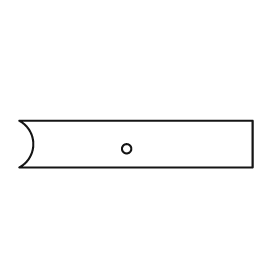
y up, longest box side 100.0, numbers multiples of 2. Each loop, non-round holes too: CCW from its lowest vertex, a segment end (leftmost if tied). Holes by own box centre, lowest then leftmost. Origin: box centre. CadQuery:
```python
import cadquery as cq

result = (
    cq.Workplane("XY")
    .moveTo(-50.0, -10.0)
    .lineTo(50.0, -10.0)
    .lineTo(50.0, 10.0)
    .lineTo(-50.0, 10.0)
    .threePointArc((-44.0, 0.0), (-50.0, -10.0))
    .close()
    .moveTo(-4.0, -2.0)
    .circle(2.0)
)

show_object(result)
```